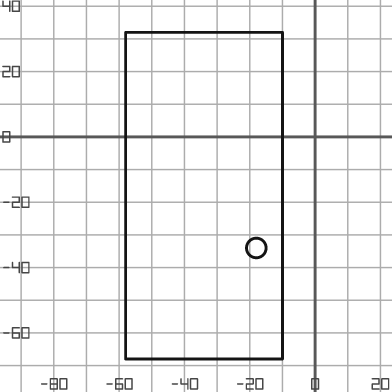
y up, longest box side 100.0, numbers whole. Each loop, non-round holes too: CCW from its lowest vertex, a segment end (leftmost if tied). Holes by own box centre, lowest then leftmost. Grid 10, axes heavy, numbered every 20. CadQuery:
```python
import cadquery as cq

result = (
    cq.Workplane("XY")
    .moveTo(-58.0, -68.0)
    .lineTo(-10.0, -68.0)
    .lineTo(-10.0, 32.0)
    .lineTo(-58.0, 32.0)
    .close()
    .moveTo(-18.0, -34.0)
    .circle(3.0)
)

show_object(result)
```